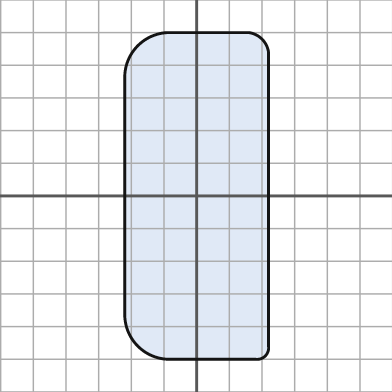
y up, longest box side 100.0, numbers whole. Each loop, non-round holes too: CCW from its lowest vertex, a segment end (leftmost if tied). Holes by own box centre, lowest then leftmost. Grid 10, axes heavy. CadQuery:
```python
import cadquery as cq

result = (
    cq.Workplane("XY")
    .moveTo(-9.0, -50.0)
    .lineTo(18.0, -50.0)
    .threePointArc((21.0, -49.0), (22.0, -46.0))
    .lineTo(22.0, 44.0)
    .threePointArc((20.0, 48.0), (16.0, 50.0))
    .lineTo(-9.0, 50.0)
    .threePointArc((-18.0, 46.0), (-22.0, 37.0))
    .lineTo(-22.0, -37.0)
    .threePointArc((-18.0, -46.0), (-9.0, -50.0))
    .close()
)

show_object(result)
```